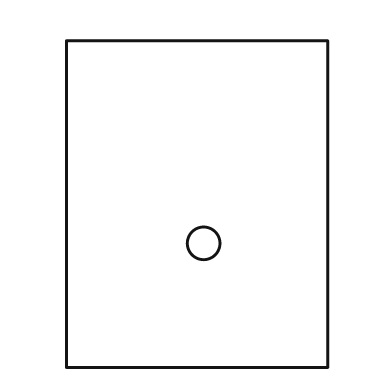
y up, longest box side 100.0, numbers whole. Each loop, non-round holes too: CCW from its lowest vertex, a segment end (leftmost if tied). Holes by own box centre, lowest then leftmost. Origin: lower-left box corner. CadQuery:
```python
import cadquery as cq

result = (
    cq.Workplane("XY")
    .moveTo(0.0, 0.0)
    .lineTo(80.0, 0.0)
    .lineTo(80.0, 100.0)
    .lineTo(0.0, 100.0)
    .close()
    .moveTo(42.0, 38.0)
    .circle(5.0)
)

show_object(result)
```